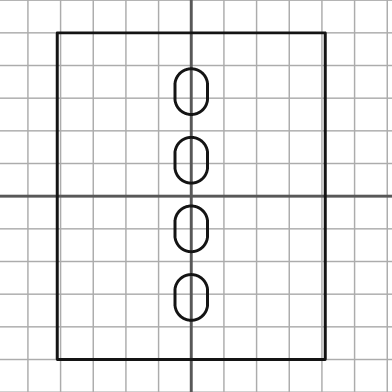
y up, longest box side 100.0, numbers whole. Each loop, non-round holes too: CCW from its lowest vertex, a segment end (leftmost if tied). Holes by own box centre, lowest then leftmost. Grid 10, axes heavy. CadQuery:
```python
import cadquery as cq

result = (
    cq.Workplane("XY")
    .moveTo(-41.0, -50.0)
    .lineTo(41.0, -50.0)
    .lineTo(41.0, 50.0)
    .lineTo(-41.0, 50.0)
    .close()
    .moveTo(-5.0, -33.0)
    .threePointArc((0.0, -38.0), (5.0, -33.0))
    .lineTo(5.0, -29.0)
    .threePointArc((0.0, -24.0), (-5.0, -29.0))
    .close()
    .moveTo(-5.0, -12.0)
    .threePointArc((0.0, -17.0), (5.0, -12.0))
    .lineTo(5.0, -8.0)
    .threePointArc((0.0, -3.0), (-5.0, -8.0))
    .close()
    .moveTo(-5.0, 9.0)
    .threePointArc((0.0, 4.0), (5.0, 9.0))
    .lineTo(5.0, 13.0)
    .threePointArc((0.0, 18.0), (-5.0, 13.0))
    .close()
    .moveTo(-5.0, 30.0)
    .threePointArc((0.0, 25.0), (5.0, 30.0))
    .lineTo(5.0, 34.0)
    .threePointArc((0.0, 39.0), (-5.0, 34.0))
    .close()
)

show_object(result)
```